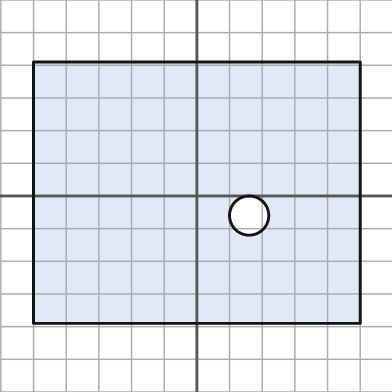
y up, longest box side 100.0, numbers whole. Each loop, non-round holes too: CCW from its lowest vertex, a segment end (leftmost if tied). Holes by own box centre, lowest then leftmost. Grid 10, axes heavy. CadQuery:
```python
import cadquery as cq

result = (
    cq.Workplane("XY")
    .moveTo(-50.0, -39.0)
    .lineTo(50.0, -39.0)
    .lineTo(50.0, 41.0)
    .lineTo(-50.0, 41.0)
    .close()
    .moveTo(16.0, -6.0)
    .circle(6.0)
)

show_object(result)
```